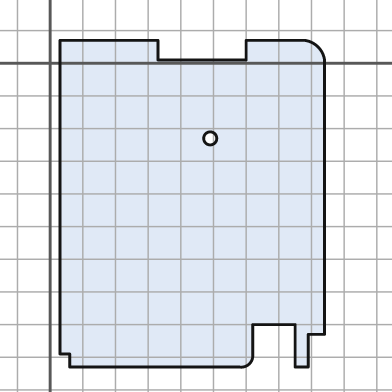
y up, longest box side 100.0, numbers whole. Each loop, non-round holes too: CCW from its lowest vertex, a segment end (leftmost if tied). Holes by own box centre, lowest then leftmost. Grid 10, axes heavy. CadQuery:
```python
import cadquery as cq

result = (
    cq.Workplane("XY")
    .moveTo(6.0, -93.0)
    .lineTo(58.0, -93.0)
    .threePointArc((61.0, -92.0), (62.0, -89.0))
    .lineTo(62.0, -80.0)
    .lineTo(75.0, -80.0)
    .lineTo(75.0, -93.0)
    .lineTo(79.0, -93.0)
    .lineTo(79.0, -83.0)
    .lineTo(84.0, -83.0)
    .lineTo(84.0, 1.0)
    .threePointArc((82.0, 5.0), (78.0, 7.0))
    .lineTo(60.0, 7.0)
    .lineTo(60.0, 1.0)
    .lineTo(33.0, 1.0)
    .lineTo(33.0, 7.0)
    .lineTo(3.0, 7.0)
    .lineTo(3.0, -89.0)
    .lineTo(6.0, -89.0)
    .close()
    .moveTo(49.0, -23.0)
    .circle(2.0)
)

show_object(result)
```